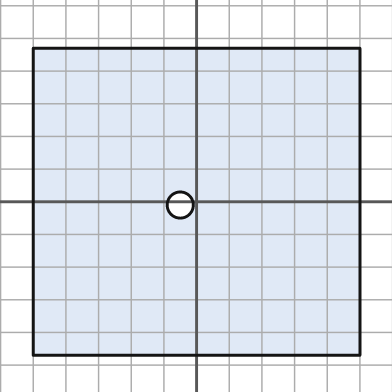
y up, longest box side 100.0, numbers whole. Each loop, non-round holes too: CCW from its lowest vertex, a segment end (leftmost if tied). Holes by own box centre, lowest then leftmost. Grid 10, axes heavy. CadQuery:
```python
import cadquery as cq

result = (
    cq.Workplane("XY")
    .moveTo(-50.0, -47.0)
    .lineTo(50.0, -47.0)
    .lineTo(50.0, 47.0)
    .lineTo(-50.0, 47.0)
    .close()
    .moveTo(-5.0, -1.0)
    .circle(4.0)
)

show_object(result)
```